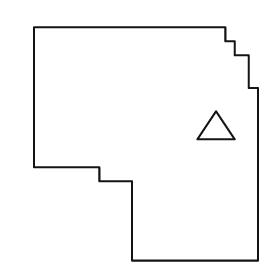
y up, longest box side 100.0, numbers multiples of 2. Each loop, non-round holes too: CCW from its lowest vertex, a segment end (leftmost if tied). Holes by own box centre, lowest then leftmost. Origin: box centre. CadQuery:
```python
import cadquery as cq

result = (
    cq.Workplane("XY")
    .moveTo(-6.0, -50.0)
    .lineTo(48.0, -50.0)
    .lineTo(48.0, 24.0)
    .lineTo(44.0, 24.0)
    .lineTo(44.0, 38.0)
    .lineTo(38.0, 38.0)
    .lineTo(38.0, 44.0)
    .lineTo(34.0, 44.0)
    .lineTo(34.0, 50.0)
    .lineTo(-48.0, 50.0)
    .lineTo(-48.0, -10.0)
    .lineTo(-20.0, -10.0)
    .lineTo(-20.0, -16.0)
    .lineTo(-6.0, -16.0)
    .close()
    .moveTo(22.0, 2.0)
    .lineTo(38.0, 2.0)
    .lineTo(30.0, 14.0)
    .close()
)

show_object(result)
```